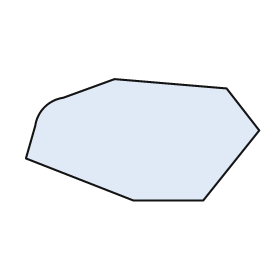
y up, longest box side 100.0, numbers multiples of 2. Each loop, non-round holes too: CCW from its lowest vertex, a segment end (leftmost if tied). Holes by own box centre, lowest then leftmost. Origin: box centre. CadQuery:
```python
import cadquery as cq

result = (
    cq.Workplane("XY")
    .moveTo(-4.0, -26.0)
    .lineTo(26.0, -26.0)
    .lineTo(50.0, 4.0)
    .lineTo(36.0, 22.0)
    .lineTo(-12.0, 26.0)
    .lineTo(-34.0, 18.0)
    .threePointArc((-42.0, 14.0), (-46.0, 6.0))
    .lineTo(-50.0, -8.0)
    .close()
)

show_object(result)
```